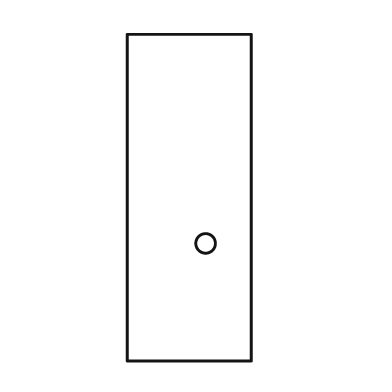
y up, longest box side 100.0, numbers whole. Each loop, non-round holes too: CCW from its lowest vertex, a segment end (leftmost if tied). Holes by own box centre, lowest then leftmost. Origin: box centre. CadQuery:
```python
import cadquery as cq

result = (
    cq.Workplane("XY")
    .moveTo(-19.0, -50.0)
    .lineTo(19.0, -50.0)
    .lineTo(19.0, 50.0)
    .lineTo(-19.0, 50.0)
    .close()
    .moveTo(5.0, -14.0)
    .circle(3.0)
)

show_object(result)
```